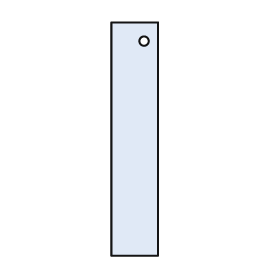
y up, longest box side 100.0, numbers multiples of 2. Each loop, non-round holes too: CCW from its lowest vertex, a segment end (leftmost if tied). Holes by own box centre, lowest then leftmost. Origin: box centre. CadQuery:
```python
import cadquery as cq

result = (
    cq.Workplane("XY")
    .moveTo(-10.0, -50.0)
    .lineTo(10.0, -50.0)
    .lineTo(10.0, 50.0)
    .lineTo(-10.0, 50.0)
    .close()
    .moveTo(4.0, 42.0)
    .circle(2.0)
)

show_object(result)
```